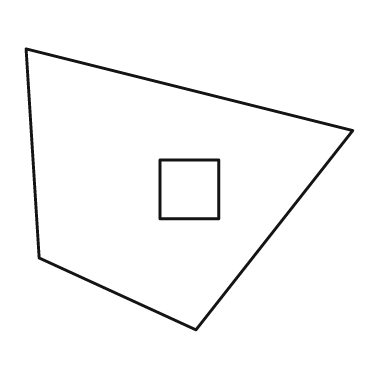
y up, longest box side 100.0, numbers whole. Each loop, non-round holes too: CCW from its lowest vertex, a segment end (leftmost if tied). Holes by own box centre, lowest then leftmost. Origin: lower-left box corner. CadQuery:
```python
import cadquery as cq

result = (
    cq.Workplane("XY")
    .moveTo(52.0, 0.0)
    .lineTo(100.0, 61.0)
    .lineTo(0.0, 86.0)
    .lineTo(4.0, 22.0)
    .close()
    .moveTo(41.0, 34.0)
    .lineTo(59.0, 34.0)
    .lineTo(59.0, 52.0)
    .lineTo(41.0, 52.0)
    .close()
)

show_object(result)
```